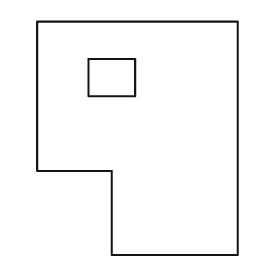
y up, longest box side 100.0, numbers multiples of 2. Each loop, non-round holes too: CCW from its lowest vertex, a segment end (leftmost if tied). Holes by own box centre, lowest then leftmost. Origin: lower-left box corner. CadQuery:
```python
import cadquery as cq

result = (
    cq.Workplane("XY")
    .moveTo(32.0, 0.0)
    .lineTo(86.0, 0.0)
    .lineTo(86.0, 100.0)
    .lineTo(0.0, 100.0)
    .lineTo(0.0, 36.0)
    .lineTo(32.0, 36.0)
    .close()
    .moveTo(22.0, 68.0)
    .lineTo(42.0, 68.0)
    .lineTo(42.0, 84.0)
    .lineTo(22.0, 84.0)
    .close()
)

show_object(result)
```